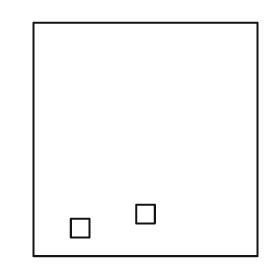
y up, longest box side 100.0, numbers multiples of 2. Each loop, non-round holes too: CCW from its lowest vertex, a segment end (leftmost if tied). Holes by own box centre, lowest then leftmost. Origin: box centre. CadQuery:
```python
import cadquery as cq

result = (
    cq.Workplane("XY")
    .moveTo(-48.0, -50.0)
    .lineTo(48.0, -50.0)
    .lineTo(48.0, 50.0)
    .lineTo(-48.0, 50.0)
    .close()
    .moveTo(-32.0, -42.0)
    .lineTo(-24.0, -42.0)
    .lineTo(-24.0, -34.0)
    .lineTo(-32.0, -34.0)
    .close()
    .moveTo(-4.0, -36.0)
    .lineTo(4.0, -36.0)
    .lineTo(4.0, -28.0)
    .lineTo(-4.0, -28.0)
    .close()
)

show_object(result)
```